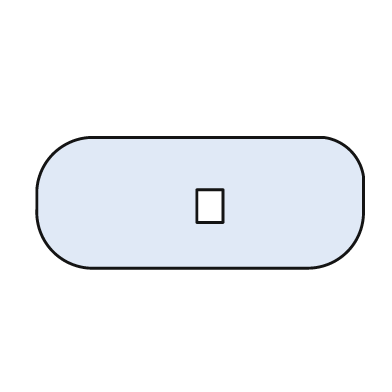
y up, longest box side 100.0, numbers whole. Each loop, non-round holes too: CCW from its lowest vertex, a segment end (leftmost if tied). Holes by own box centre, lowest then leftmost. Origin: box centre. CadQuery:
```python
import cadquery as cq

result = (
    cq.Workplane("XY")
    .moveTo(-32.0, -20.0)
    .lineTo(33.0, -20.0)
    .threePointArc((45.0, -15.0), (50.0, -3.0))
    .lineTo(50.0, 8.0)
    .threePointArc((46.0, 16.0), (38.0, 20.0))
    .lineTo(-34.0, 20.0)
    .threePointArc((-45.0, 15.0), (-50.0, 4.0))
    .lineTo(-50.0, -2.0)
    .threePointArc((-45.0, -15.0), (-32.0, -20.0))
    .close()
    .moveTo(-1.0, -6.0)
    .lineTo(7.0, -6.0)
    .lineTo(7.0, 4.0)
    .lineTo(-1.0, 4.0)
    .close()
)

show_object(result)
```